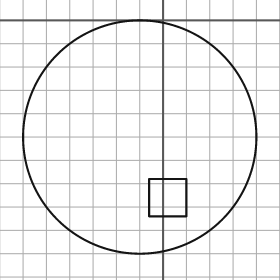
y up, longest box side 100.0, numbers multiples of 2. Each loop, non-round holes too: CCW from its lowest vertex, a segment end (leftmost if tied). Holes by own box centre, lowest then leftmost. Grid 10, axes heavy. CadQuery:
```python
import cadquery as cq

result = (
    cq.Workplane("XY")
    .moveTo(-10.0, -50.0)
    .circle(50.0)
    .moveTo(-6.0, -84.0)
    .lineTo(10.0, -84.0)
    .lineTo(10.0, -68.0)
    .lineTo(-6.0, -68.0)
    .close()
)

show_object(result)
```